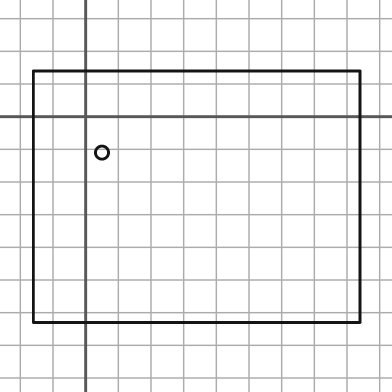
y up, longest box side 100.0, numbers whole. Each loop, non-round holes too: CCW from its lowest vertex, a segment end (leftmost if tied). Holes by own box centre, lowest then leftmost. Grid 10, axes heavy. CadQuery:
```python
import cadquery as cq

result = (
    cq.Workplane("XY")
    .moveTo(-16.0, -63.0)
    .lineTo(84.0, -63.0)
    .lineTo(84.0, 14.0)
    .lineTo(-16.0, 14.0)
    .close()
    .moveTo(5.0, -11.0)
    .circle(2.0)
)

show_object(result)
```